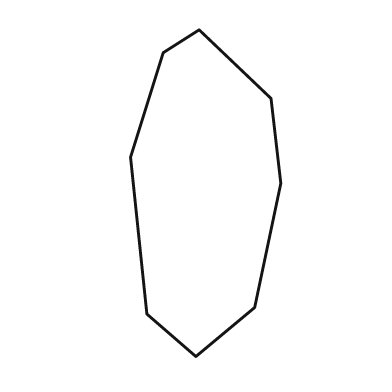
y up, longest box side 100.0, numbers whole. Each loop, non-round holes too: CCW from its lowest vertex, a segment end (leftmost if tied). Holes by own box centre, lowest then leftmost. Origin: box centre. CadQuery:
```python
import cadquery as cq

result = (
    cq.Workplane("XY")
    .moveTo(-3.0, -50.0)
    .lineTo(15.0, -35.0)
    .lineTo(23.0, 3.0)
    .lineTo(20.0, 29.0)
    .lineTo(-2.0, 50.0)
    .lineTo(-13.0, 43.0)
    .lineTo(-23.0, 11.0)
    .lineTo(-18.0, -37.0)
    .close()
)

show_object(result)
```